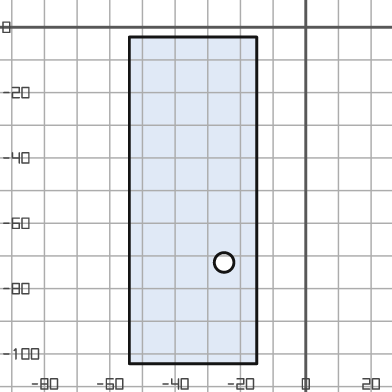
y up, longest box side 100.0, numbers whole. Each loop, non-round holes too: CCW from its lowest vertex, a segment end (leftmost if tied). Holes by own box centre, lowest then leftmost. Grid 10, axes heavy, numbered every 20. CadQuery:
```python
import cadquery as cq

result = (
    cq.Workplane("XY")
    .moveTo(-54.0, -103.0)
    .lineTo(-15.0, -103.0)
    .lineTo(-15.0, -3.0)
    .lineTo(-54.0, -3.0)
    .close()
    .moveTo(-25.0, -72.0)
    .circle(3.0)
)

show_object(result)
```